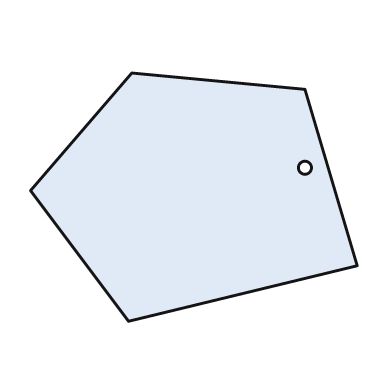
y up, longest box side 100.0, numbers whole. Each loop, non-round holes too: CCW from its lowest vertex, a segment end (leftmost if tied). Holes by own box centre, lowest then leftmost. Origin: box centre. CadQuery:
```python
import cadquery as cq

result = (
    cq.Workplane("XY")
    .moveTo(-20.0, -38.0)
    .lineTo(50.0, -21.0)
    .lineTo(34.0, 33.0)
    .lineTo(-19.0, 38.0)
    .lineTo(-50.0, 2.0)
    .close()
    .moveTo(34.0, 9.0)
    .circle(2.0)
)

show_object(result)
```